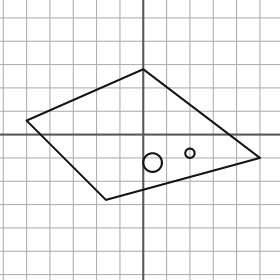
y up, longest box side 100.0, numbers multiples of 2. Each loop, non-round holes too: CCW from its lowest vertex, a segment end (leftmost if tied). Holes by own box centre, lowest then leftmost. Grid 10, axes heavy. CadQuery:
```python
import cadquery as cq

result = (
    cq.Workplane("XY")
    .moveTo(-16.0, -28.0)
    .lineTo(50.0, -10.0)
    .lineTo(0.0, 28.0)
    .lineTo(-50.0, 6.0)
    .close()
    .moveTo(4.0, -12.0)
    .circle(4.0)
    .moveTo(20.0, -8.0)
    .circle(2.0)
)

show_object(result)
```